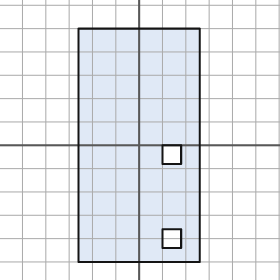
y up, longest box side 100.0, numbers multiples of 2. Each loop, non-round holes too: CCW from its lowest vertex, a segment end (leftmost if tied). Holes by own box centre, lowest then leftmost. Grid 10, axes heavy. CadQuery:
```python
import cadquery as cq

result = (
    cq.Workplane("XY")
    .moveTo(-26.0, -50.0)
    .lineTo(26.0, -50.0)
    .lineTo(26.0, 50.0)
    .lineTo(-26.0, 50.0)
    .close()
    .moveTo(10.0, -44.0)
    .lineTo(18.0, -44.0)
    .lineTo(18.0, -36.0)
    .lineTo(10.0, -36.0)
    .close()
    .moveTo(10.0, -8.0)
    .lineTo(18.0, -8.0)
    .lineTo(18.0, 0.0)
    .lineTo(10.0, 0.0)
    .close()
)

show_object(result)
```